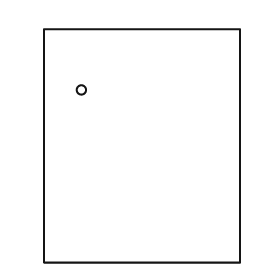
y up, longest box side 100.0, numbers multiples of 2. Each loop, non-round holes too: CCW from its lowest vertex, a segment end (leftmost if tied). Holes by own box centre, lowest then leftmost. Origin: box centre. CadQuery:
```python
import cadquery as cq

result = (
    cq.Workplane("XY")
    .moveTo(-42.0, -50.0)
    .lineTo(42.0, -50.0)
    .lineTo(42.0, 50.0)
    .lineTo(-42.0, 50.0)
    .close()
    .moveTo(-26.0, 24.0)
    .circle(2.0)
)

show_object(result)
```